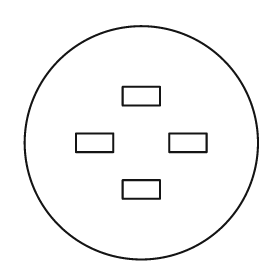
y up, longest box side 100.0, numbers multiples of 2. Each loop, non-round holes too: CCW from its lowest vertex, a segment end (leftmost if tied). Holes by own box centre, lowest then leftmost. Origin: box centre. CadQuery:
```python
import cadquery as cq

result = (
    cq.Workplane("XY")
    .moveTo(0.0, 0.0)
    .circle(50.0)
    .moveTo(-8.0, -24.0)
    .lineTo(8.0, -24.0)
    .lineTo(8.0, -16.0)
    .lineTo(-8.0, -16.0)
    .close()
    .moveTo(-28.0, -4.0)
    .lineTo(-12.0, -4.0)
    .lineTo(-12.0, 4.0)
    .lineTo(-28.0, 4.0)
    .close()
    .moveTo(12.0, -4.0)
    .lineTo(28.0, -4.0)
    .lineTo(28.0, 4.0)
    .lineTo(12.0, 4.0)
    .close()
    .moveTo(-8.0, 16.0)
    .lineTo(8.0, 16.0)
    .lineTo(8.0, 24.0)
    .lineTo(-8.0, 24.0)
    .close()
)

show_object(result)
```